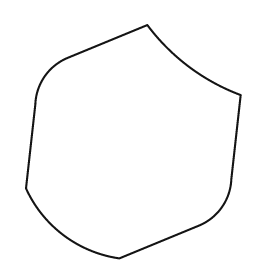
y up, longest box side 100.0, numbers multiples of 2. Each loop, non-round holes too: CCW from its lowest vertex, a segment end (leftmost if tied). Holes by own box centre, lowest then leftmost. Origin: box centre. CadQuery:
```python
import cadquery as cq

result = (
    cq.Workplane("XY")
    .moveTo(-6.0, -50.0)
    .lineTo(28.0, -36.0)
    .threePointArc((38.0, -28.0), (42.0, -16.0))
    .lineTo(46.0, 20.0)
    .threePointArc((24.0, 32.0), (6.0, 50.0))
    .lineTo(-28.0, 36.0)
    .threePointArc((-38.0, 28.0), (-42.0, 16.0))
    .lineTo(-46.0, -20.0)
    .threePointArc((-30.0, -40.0), (-6.0, -50.0))
    .close()
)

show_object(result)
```